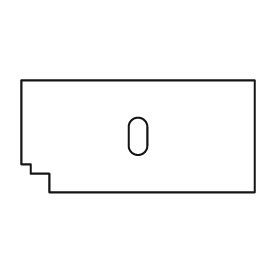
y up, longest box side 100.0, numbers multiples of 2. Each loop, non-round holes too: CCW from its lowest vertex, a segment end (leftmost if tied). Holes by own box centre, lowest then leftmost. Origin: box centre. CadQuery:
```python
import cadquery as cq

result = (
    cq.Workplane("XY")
    .moveTo(-38.0, -24.0)
    .lineTo(50.0, -24.0)
    .lineTo(50.0, 24.0)
    .lineTo(-50.0, 24.0)
    .lineTo(-50.0, -12.0)
    .lineTo(-46.0, -12.0)
    .lineTo(-46.0, -16.0)
    .lineTo(-38.0, -16.0)
    .close()
    .moveTo(-4.0, -4.0)
    .threePointArc((0.0, -8.0), (4.0, -4.0))
    .lineTo(4.0, 4.0)
    .threePointArc((0.0, 8.0), (-4.0, 4.0))
    .close()
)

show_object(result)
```